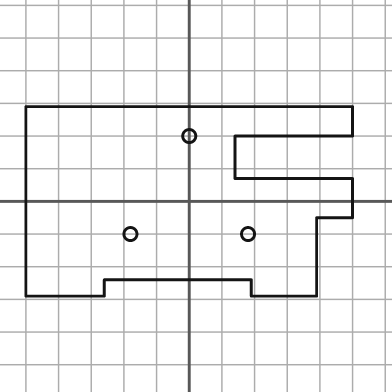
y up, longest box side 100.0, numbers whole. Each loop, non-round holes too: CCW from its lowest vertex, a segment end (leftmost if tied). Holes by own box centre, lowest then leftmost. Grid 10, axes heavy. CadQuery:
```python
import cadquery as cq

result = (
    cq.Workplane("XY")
    .moveTo(-50.0, -29.0)
    .lineTo(-26.0, -29.0)
    .lineTo(-26.0, -24.0)
    .lineTo(19.0, -24.0)
    .lineTo(19.0, -29.0)
    .lineTo(39.0, -29.0)
    .lineTo(39.0, -5.0)
    .lineTo(50.0, -5.0)
    .lineTo(50.0, 7.0)
    .lineTo(14.0, 7.0)
    .lineTo(14.0, 20.0)
    .lineTo(50.0, 20.0)
    .lineTo(50.0, 29.0)
    .lineTo(-50.0, 29.0)
    .close()
    .moveTo(-18.0, -10.0)
    .circle(2.0)
    .moveTo(18.0, -10.0)
    .circle(2.0)
    .moveTo(0.0, 20.0)
    .circle(2.0)
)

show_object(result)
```